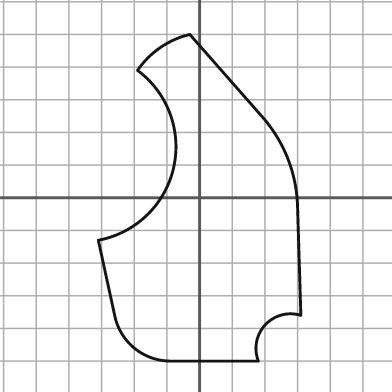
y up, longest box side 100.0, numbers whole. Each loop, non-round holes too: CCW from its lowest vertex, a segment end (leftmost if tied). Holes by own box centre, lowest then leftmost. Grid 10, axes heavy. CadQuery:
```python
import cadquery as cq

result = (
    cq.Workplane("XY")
    .moveTo(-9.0, -50.0)
    .lineTo(18.0, -50.0)
    .threePointArc((20.0, -39.0), (31.0, -36.0))
    .lineTo(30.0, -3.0)
    .threePointArc((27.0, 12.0), (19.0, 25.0))
    .lineTo(-3.0, 50.0)
    .threePointArc((-12.0, 46.0), (-19.0, 39.0))
    .threePointArc((-8.0, 9.0), (-31.0, -13.0))
    .lineTo(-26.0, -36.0)
    .threePointArc((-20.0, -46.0), (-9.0, -50.0))
    .close()
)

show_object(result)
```